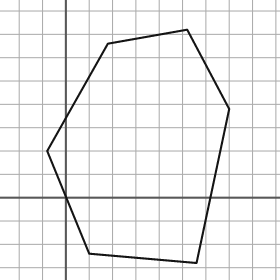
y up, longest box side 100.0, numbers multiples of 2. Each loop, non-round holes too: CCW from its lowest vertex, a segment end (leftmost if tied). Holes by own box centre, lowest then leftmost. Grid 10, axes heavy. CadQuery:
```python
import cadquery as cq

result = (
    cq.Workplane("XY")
    .moveTo(56.0, -28.0)
    .lineTo(70.0, 38.0)
    .lineTo(52.0, 72.0)
    .lineTo(18.0, 66.0)
    .lineTo(-8.0, 20.0)
    .lineTo(10.0, -24.0)
    .close()
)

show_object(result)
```